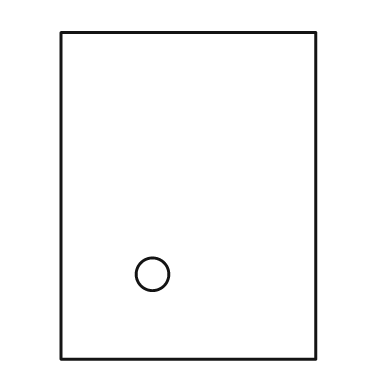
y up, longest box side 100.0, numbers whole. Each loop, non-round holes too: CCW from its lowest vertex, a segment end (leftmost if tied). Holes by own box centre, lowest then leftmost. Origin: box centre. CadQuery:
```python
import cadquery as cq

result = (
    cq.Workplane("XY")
    .moveTo(-39.0, -50.0)
    .lineTo(39.0, -50.0)
    .lineTo(39.0, 50.0)
    .lineTo(-39.0, 50.0)
    .close()
    .moveTo(-11.0, -24.0)
    .circle(5.0)
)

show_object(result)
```